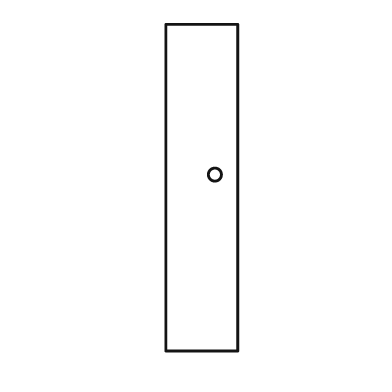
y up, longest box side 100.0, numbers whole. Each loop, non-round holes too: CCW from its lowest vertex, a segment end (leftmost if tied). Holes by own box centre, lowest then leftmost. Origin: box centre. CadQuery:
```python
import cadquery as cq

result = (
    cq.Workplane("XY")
    .moveTo(-11.0, -50.0)
    .lineTo(11.0, -50.0)
    .lineTo(11.0, 50.0)
    .lineTo(-11.0, 50.0)
    .close()
    .moveTo(4.0, 4.0)
    .circle(2.0)
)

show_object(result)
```